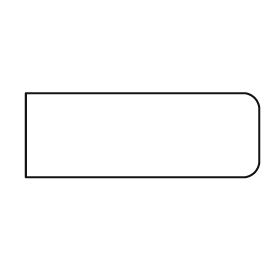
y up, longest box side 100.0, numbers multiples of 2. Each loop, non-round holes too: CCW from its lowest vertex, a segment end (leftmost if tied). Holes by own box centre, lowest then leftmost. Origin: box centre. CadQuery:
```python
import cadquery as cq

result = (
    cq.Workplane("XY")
    .moveTo(-50.0, -18.0)
    .lineTo(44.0, -18.0)
    .threePointArc((48.0, -16.0), (50.0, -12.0))
    .lineTo(50.0, 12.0)
    .threePointArc((48.0, 16.0), (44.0, 18.0))
    .lineTo(-50.0, 18.0)
    .close()
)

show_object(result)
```